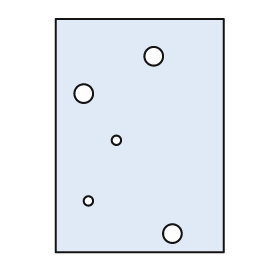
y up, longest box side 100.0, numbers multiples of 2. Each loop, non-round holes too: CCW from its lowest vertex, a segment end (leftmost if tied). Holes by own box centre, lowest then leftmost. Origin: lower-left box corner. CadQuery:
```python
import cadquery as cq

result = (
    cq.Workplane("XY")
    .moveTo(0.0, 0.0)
    .lineTo(72.0, 0.0)
    .lineTo(72.0, 100.0)
    .lineTo(0.0, 100.0)
    .close()
    .moveTo(50.0, 8.0)
    .circle(4.0)
    .moveTo(14.0, 22.0)
    .circle(2.0)
    .moveTo(26.0, 48.0)
    .circle(2.0)
    .moveTo(12.0, 68.0)
    .circle(4.0)
    .moveTo(42.0, 84.0)
    .circle(4.0)
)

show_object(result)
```